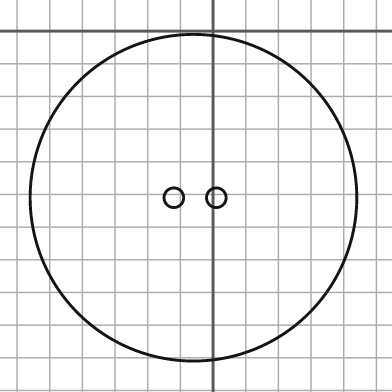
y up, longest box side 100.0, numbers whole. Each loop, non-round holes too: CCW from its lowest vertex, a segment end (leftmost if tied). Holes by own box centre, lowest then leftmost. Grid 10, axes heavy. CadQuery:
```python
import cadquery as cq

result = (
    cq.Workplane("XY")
    .moveTo(-6.0, -51.0)
    .circle(50.0)
    .moveTo(-12.0, -51.0)
    .circle(3.0)
    .moveTo(1.0, -51.0)
    .circle(3.0)
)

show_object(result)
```